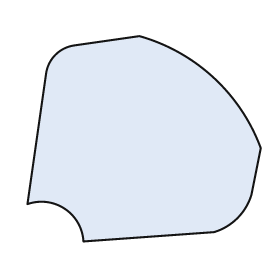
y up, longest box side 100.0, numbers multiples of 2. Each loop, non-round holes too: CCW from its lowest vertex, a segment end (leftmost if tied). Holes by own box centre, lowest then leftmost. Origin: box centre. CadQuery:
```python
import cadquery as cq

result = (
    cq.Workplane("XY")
    .moveTo(-26.0, -44.0)
    .lineTo(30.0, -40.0)
    .threePointArc((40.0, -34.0), (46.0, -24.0))
    .lineTo(50.0, -4.0)
    .threePointArc((30.0, 26.0), (-2.0, 44.0))
    .lineTo(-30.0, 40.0)
    .threePointArc((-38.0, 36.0), (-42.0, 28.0))
    .lineTo(-50.0, -28.0)
    .threePointArc((-34.0, -30.0), (-26.0, -44.0))
    .close()
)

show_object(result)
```